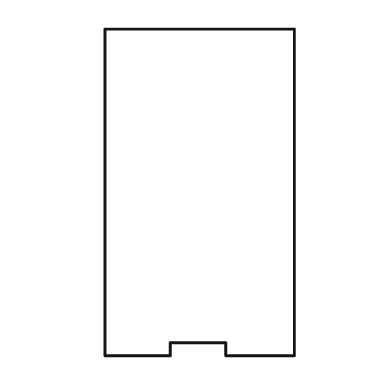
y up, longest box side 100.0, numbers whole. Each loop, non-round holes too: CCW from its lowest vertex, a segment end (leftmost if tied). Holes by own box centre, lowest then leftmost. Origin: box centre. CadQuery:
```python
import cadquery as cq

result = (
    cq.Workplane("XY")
    .moveTo(-29.0, -50.0)
    .lineTo(-9.0, -50.0)
    .lineTo(-9.0, -46.0)
    .lineTo(8.0, -46.0)
    .lineTo(8.0, -50.0)
    .lineTo(29.0, -50.0)
    .lineTo(29.0, 50.0)
    .lineTo(-29.0, 50.0)
    .close()
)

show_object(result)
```